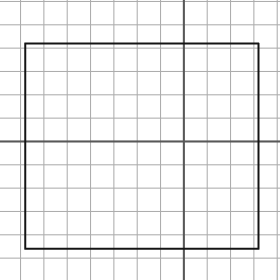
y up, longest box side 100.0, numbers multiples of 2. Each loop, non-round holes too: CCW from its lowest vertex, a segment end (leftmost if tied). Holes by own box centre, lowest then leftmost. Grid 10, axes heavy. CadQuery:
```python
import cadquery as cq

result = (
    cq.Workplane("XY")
    .moveTo(-68.0, -46.0)
    .lineTo(32.0, -46.0)
    .lineTo(32.0, 42.0)
    .lineTo(-68.0, 42.0)
    .close()
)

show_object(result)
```